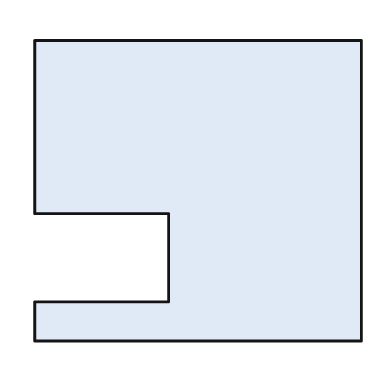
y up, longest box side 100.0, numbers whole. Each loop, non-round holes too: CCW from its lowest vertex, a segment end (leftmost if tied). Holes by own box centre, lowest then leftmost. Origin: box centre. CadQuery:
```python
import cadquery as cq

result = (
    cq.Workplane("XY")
    .moveTo(-50.0, -46.0)
    .lineTo(50.0, -46.0)
    .lineTo(50.0, 46.0)
    .lineTo(-50.0, 46.0)
    .lineTo(-50.0, -7.0)
    .lineTo(-9.0, -7.0)
    .lineTo(-9.0, -34.0)
    .lineTo(-50.0, -34.0)
    .close()
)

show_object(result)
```